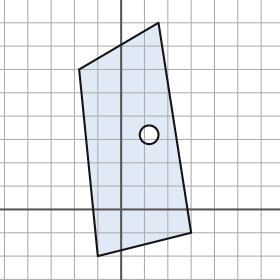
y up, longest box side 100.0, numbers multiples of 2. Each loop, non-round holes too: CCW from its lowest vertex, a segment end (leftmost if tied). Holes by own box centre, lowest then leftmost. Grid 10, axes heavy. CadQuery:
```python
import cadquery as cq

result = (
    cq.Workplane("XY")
    .moveTo(-10.0, -20.0)
    .lineTo(30.0, -10.0)
    .lineTo(16.0, 80.0)
    .lineTo(-18.0, 60.0)
    .close()
    .moveTo(12.0, 32.0)
    .circle(4.0)
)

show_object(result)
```